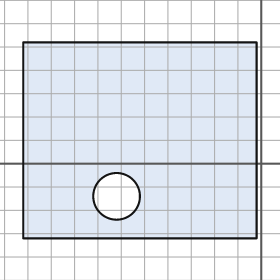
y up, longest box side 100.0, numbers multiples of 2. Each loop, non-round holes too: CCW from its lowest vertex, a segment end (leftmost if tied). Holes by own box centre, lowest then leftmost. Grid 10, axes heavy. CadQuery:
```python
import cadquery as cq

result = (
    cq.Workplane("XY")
    .moveTo(-102.0, -32.0)
    .lineTo(-2.0, -32.0)
    .lineTo(-2.0, 52.0)
    .lineTo(-102.0, 52.0)
    .close()
    .moveTo(-62.0, -14.0)
    .circle(10.0)
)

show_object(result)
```